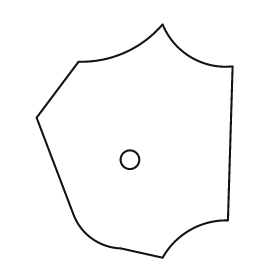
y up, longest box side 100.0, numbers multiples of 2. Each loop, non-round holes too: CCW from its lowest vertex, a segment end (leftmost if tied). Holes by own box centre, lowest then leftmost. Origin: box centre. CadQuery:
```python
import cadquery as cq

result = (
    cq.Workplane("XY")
    .moveTo(12.0, -50.0)
    .threePointArc((24.0, -38.0), (40.0, -34.0))
    .lineTo(42.0, 32.0)
    .threePointArc((24.0, 36.0), (12.0, 50.0))
    .threePointArc((-4.0, 38.0), (-24.0, 34.0))
    .lineTo(-42.0, 10.0)
    .lineTo(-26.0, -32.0)
    .threePointArc((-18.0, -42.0), (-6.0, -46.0))
    .close()
    .moveTo(-2.0, -8.0)
    .circle(4.0)
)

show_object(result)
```